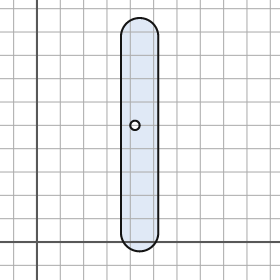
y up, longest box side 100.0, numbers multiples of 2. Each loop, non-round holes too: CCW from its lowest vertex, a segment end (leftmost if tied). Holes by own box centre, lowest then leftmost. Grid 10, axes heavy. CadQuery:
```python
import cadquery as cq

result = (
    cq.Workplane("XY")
    .moveTo(36.0, 4.0)
    .threePointArc((44.0, -4.0), (52.0, 4.0))
    .lineTo(52.0, 88.0)
    .threePointArc((44.0, 96.0), (36.0, 88.0))
    .close()
    .moveTo(42.0, 50.0)
    .circle(2.0)
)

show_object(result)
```